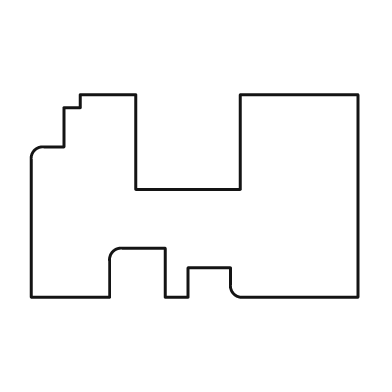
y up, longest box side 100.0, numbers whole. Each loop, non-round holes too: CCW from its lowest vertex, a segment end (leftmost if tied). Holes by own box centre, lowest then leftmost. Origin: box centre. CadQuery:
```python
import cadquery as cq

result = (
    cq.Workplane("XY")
    .moveTo(-50.0, -31.0)
    .lineTo(-26.0, -31.0)
    .lineTo(-26.0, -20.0)
    .threePointArc((-25.0, -17.0), (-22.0, -16.0))
    .lineTo(-9.0, -16.0)
    .lineTo(-9.0, -31.0)
    .lineTo(-2.0, -31.0)
    .lineTo(-2.0, -22.0)
    .lineTo(11.0, -22.0)
    .lineTo(11.0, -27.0)
    .threePointArc((12.0, -30.0), (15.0, -31.0))
    .lineTo(50.0, -31.0)
    .lineTo(50.0, 31.0)
    .lineTo(14.0, 31.0)
    .lineTo(14.0, 2.0)
    .lineTo(-18.0, 2.0)
    .lineTo(-18.0, 31.0)
    .lineTo(-35.0, 31.0)
    .lineTo(-35.0, 27.0)
    .lineTo(-40.0, 27.0)
    .lineTo(-40.0, 15.0)
    .lineTo(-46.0, 15.0)
    .threePointArc((-49.0, 14.0), (-50.0, 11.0))
    .close()
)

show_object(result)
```